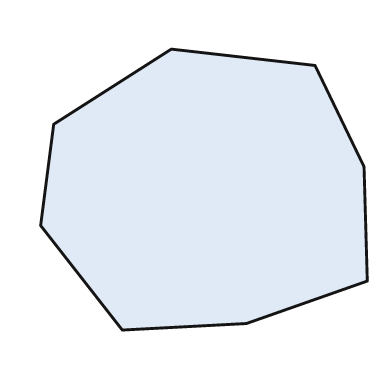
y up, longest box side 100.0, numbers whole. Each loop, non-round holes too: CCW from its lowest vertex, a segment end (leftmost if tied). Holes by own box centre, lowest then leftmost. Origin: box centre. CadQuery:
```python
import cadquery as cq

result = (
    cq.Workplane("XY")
    .moveTo(-25.0, -43.0)
    .lineTo(13.0, -41.0)
    .lineTo(50.0, -28.0)
    .lineTo(49.0, 7.0)
    .lineTo(34.0, 38.0)
    .lineTo(-10.0, 43.0)
    .lineTo(-46.0, 20.0)
    .lineTo(-50.0, -11.0)
    .close()
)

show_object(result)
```